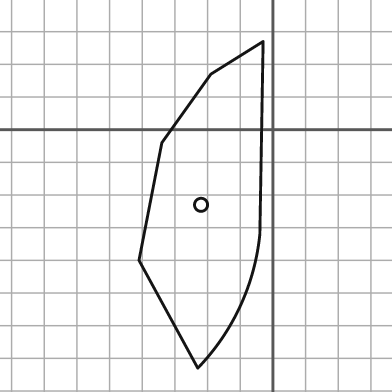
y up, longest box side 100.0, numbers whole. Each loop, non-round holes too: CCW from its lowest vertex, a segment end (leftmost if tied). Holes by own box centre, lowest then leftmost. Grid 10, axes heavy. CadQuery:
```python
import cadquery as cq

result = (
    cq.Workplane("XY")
    .moveTo(-23.0, -73.0)
    .threePointArc((-10.0, -54.0), (-4.0, -32.0))
    .lineTo(-3.0, 27.0)
    .lineTo(-19.0, 17.0)
    .lineTo(-34.0, -4.0)
    .lineTo(-41.0, -40.0)
    .close()
    .moveTo(-22.0, -23.0)
    .circle(2.0)
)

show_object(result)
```